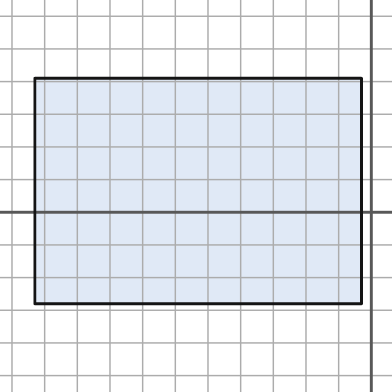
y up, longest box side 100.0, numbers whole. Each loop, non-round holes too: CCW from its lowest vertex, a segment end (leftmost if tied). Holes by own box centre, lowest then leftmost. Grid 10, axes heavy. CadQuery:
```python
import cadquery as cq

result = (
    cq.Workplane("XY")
    .moveTo(-103.0, -28.0)
    .lineTo(-3.0, -28.0)
    .lineTo(-3.0, 41.0)
    .lineTo(-103.0, 41.0)
    .close()
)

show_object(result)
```